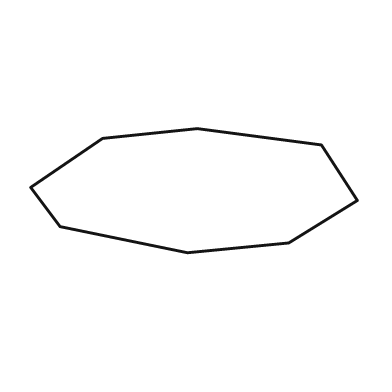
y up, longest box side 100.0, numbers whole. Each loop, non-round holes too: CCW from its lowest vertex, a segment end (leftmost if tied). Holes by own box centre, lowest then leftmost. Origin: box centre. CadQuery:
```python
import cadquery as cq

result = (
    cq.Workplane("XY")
    .moveTo(-2.0, -19.0)
    .lineTo(29.0, -16.0)
    .lineTo(50.0, -3.0)
    .lineTo(39.0, 14.0)
    .lineTo(1.0, 19.0)
    .lineTo(-28.0, 16.0)
    .lineTo(-50.0, 1.0)
    .lineTo(-41.0, -11.0)
    .close()
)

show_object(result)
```